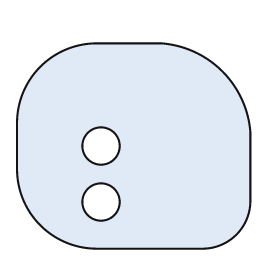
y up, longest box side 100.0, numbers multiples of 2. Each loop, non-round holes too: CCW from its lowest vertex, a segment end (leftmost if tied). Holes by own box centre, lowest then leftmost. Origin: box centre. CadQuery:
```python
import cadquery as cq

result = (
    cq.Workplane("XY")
    .moveTo(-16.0, -44.0)
    .lineTo(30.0, -44.0)
    .threePointArc((44.0, -38.0), (50.0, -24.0))
    .lineTo(50.0, 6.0)
    .threePointArc((38.0, 32.0), (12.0, 44.0))
    .lineTo(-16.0, 44.0)
    .threePointArc((-40.0, 34.0), (-50.0, 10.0))
    .lineTo(-50.0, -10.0)
    .threePointArc((-40.0, -34.0), (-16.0, -44.0))
    .close()
    .moveTo(-14.0, -24.0)
    .circle(8.0)
    .moveTo(-14.0, 0.0)
    .circle(8.0)
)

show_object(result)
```